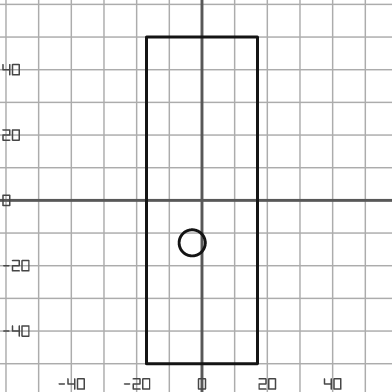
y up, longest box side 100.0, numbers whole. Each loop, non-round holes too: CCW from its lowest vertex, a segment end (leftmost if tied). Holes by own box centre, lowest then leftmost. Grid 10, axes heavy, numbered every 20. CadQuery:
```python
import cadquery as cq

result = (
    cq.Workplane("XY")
    .moveTo(-17.0, -50.0)
    .lineTo(17.0, -50.0)
    .lineTo(17.0, 50.0)
    .lineTo(-17.0, 50.0)
    .close()
    .moveTo(-3.0, -13.0)
    .circle(4.0)
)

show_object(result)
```